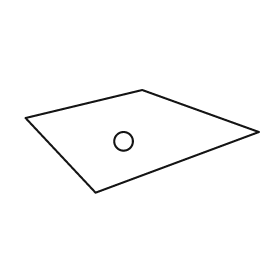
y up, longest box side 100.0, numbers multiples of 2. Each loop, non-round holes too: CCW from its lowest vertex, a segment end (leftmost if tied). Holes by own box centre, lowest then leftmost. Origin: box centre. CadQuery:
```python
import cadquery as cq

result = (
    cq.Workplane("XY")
    .moveTo(-20.0, -22.0)
    .lineTo(50.0, 4.0)
    .lineTo(0.0, 22.0)
    .lineTo(-50.0, 10.0)
    .close()
    .moveTo(-8.0, 0.0)
    .circle(4.0)
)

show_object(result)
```